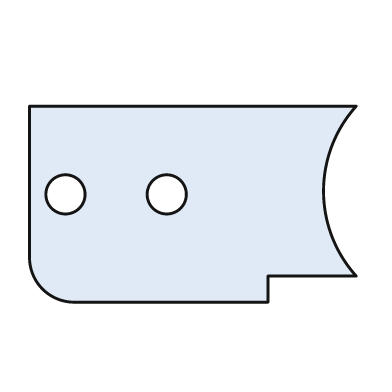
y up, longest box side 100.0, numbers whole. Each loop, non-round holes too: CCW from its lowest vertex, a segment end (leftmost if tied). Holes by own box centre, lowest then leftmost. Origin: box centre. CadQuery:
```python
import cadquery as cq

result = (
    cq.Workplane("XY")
    .moveTo(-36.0, -30.0)
    .lineTo(23.0, -30.0)
    .lineTo(23.0, -22.0)
    .lineTo(50.0, -22.0)
    .threePointArc((40.0, 4.0), (50.0, 30.0))
    .lineTo(-50.0, 30.0)
    .lineTo(-50.0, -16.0)
    .threePointArc((-46.0, -26.0), (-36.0, -30.0))
    .close()
    .moveTo(-39.0, 3.0)
    .circle(6.0)
    .moveTo(-8.0, 3.0)
    .circle(6.0)
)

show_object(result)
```